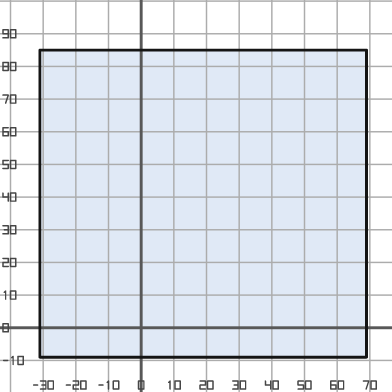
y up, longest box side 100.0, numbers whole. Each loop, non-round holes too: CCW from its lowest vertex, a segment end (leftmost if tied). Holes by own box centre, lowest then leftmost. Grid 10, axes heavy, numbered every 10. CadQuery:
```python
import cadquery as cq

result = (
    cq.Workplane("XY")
    .moveTo(-31.0, -9.0)
    .lineTo(69.0, -9.0)
    .lineTo(69.0, 85.0)
    .lineTo(-31.0, 85.0)
    .close()
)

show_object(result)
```